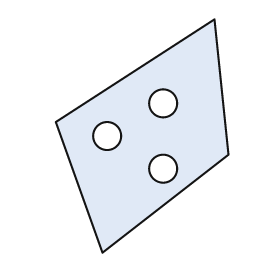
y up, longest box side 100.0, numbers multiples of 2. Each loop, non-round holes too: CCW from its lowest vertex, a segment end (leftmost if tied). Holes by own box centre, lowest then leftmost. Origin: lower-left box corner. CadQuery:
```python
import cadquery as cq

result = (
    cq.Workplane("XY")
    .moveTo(20.0, 0.0)
    .lineTo(74.0, 42.0)
    .lineTo(68.0, 100.0)
    .lineTo(0.0, 56.0)
    .close()
    .moveTo(46.0, 36.0)
    .circle(6.0)
    .moveTo(22.0, 50.0)
    .circle(6.0)
    .moveTo(46.0, 64.0)
    .circle(6.0)
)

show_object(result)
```